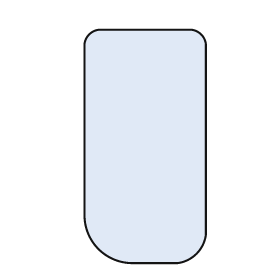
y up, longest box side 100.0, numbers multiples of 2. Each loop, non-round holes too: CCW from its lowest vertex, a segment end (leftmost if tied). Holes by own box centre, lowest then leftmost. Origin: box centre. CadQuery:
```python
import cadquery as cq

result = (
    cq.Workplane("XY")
    .moveTo(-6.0, -50.0)
    .lineTo(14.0, -50.0)
    .threePointArc((22.0, -46.0), (26.0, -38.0))
    .lineTo(26.0, 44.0)
    .threePointArc((24.0, 48.0), (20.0, 50.0))
    .lineTo(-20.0, 50.0)
    .threePointArc((-24.0, 48.0), (-26.0, 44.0))
    .lineTo(-26.0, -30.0)
    .threePointArc((-20.0, -44.0), (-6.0, -50.0))
    .close()
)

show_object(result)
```